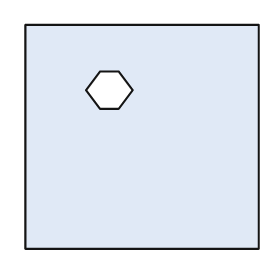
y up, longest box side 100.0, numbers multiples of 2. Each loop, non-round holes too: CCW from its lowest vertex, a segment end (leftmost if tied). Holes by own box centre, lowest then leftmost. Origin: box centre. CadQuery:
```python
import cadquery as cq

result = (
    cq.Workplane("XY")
    .moveTo(-50.0, -48.0)
    .lineTo(50.0, -48.0)
    .lineTo(50.0, 48.0)
    .lineTo(-50.0, 48.0)
    .close()
    .moveTo(-18.0, 12.0)
    .lineTo(-10.0, 12.0)
    .lineTo(-4.0, 20.0)
    .lineTo(-10.0, 28.0)
    .lineTo(-18.0, 28.0)
    .lineTo(-24.0, 20.0)
    .close()
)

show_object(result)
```